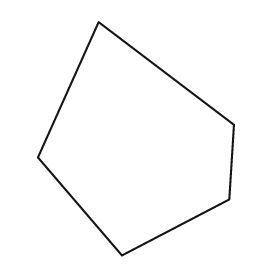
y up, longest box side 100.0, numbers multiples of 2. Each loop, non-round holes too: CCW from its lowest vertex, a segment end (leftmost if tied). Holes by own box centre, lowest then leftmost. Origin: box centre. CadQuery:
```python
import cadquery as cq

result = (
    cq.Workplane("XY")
    .moveTo(-6.0, -50.0)
    .lineTo(40.0, -26.0)
    .lineTo(42.0, 6.0)
    .lineTo(-16.0, 50.0)
    .lineTo(-42.0, -8.0)
    .close()
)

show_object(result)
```